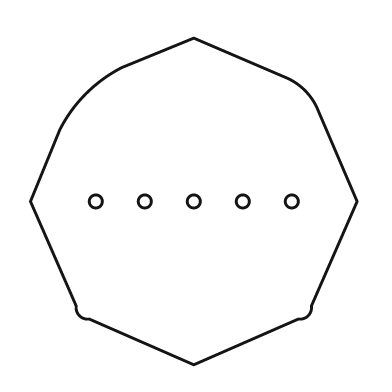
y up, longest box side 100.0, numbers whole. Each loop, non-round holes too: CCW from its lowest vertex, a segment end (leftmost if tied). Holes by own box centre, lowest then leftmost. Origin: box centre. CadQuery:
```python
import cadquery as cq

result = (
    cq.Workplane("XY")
    .moveTo(0.0, -50.0)
    .lineTo(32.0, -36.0)
    .threePointArc((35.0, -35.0), (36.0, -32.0))
    .lineTo(50.0, 0.0)
    .lineTo(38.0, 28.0)
    .threePointArc((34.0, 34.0), (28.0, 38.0))
    .lineTo(0.0, 50.0)
    .lineTo(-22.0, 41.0)
    .threePointArc((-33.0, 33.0), (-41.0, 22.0))
    .lineTo(-50.0, 0.0)
    .lineTo(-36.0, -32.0)
    .threePointArc((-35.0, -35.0), (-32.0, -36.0))
    .close()
    .moveTo(-30.0, 0.0)
    .circle(2.0)
    .moveTo(-15.0, 0.0)
    .circle(2.0)
    .moveTo(0.0, 0.0)
    .circle(2.0)
    .moveTo(15.0, 0.0)
    .circle(2.0)
    .moveTo(30.0, 0.0)
    .circle(2.0)
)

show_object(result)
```